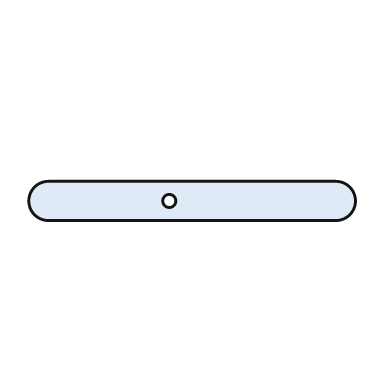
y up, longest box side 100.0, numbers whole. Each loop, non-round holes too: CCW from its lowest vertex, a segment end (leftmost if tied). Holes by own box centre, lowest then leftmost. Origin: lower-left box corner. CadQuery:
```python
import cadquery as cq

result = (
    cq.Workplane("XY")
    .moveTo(6.0, 0.0)
    .lineTo(94.0, 0.0)
    .threePointArc((100.0, 6.0), (94.0, 12.0))
    .lineTo(6.0, 12.0)
    .threePointArc((0.0, 6.0), (6.0, 0.0))
    .close()
    .moveTo(43.0, 6.0)
    .circle(2.0)
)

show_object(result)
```